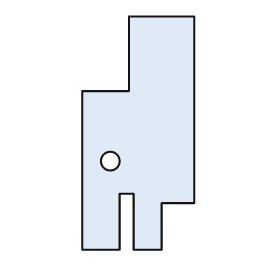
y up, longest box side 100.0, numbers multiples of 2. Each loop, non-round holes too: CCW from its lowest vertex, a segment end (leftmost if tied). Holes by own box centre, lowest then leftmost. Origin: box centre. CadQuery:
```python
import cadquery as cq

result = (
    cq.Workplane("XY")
    .moveTo(-24.0, -50.0)
    .lineTo(-8.0, -50.0)
    .lineTo(-8.0, -26.0)
    .lineTo(-2.0, -26.0)
    .lineTo(-2.0, -50.0)
    .lineTo(10.0, -50.0)
    .lineTo(10.0, -30.0)
    .lineTo(24.0, -30.0)
    .lineTo(24.0, 50.0)
    .lineTo(-4.0, 50.0)
    .lineTo(-4.0, 18.0)
    .lineTo(-24.0, 18.0)
    .close()
    .moveTo(-12.0, -12.0)
    .circle(4.0)
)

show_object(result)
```